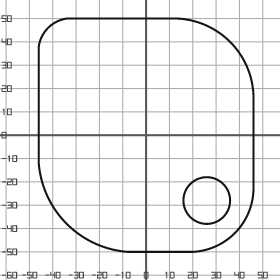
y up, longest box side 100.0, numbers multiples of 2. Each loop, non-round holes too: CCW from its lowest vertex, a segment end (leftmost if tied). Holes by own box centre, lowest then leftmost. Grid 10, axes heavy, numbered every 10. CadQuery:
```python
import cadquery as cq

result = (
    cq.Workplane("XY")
    .moveTo(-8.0, -50.0)
    .lineTo(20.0, -50.0)
    .threePointArc((38.0, -42.0), (46.0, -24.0))
    .lineTo(46.0, 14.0)
    .threePointArc((36.0, 40.0), (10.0, 50.0))
    .lineTo(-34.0, 50.0)
    .threePointArc((-42.0, 46.0), (-46.0, 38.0))
    .lineTo(-46.0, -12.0)
    .threePointArc((-34.0, -38.0), (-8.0, -50.0))
    .close()
    .moveTo(26.0, -28.0)
    .circle(10.0)
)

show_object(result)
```